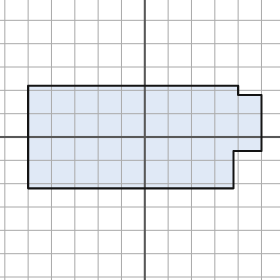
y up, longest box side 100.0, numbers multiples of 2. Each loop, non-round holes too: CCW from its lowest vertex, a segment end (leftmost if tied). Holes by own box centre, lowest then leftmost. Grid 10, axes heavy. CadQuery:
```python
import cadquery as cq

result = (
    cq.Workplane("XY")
    .moveTo(-50.0, -22.0)
    .lineTo(38.0, -22.0)
    .lineTo(38.0, -6.0)
    .lineTo(50.0, -6.0)
    .lineTo(50.0, 18.0)
    .lineTo(40.0, 18.0)
    .lineTo(40.0, 22.0)
    .lineTo(-50.0, 22.0)
    .close()
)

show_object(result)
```